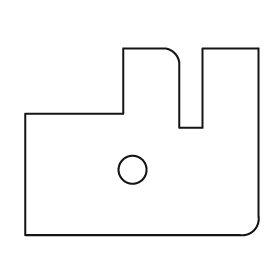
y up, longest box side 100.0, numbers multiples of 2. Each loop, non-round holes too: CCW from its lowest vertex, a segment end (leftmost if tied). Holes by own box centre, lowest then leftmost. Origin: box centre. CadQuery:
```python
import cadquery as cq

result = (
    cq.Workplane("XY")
    .moveTo(-50.0, -40.0)
    .lineTo(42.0, -40.0)
    .threePointArc((48.0, -38.0), (50.0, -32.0))
    .lineTo(50.0, 40.0)
    .lineTo(26.0, 40.0)
    .lineTo(26.0, 6.0)
    .lineTo(16.0, 6.0)
    .lineTo(16.0, 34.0)
    .threePointArc((14.0, 38.0), (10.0, 40.0))
    .lineTo(-8.0, 40.0)
    .lineTo(-8.0, 12.0)
    .lineTo(-50.0, 12.0)
    .close()
    .moveTo(-4.0, -12.0)
    .circle(6.0)
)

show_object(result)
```